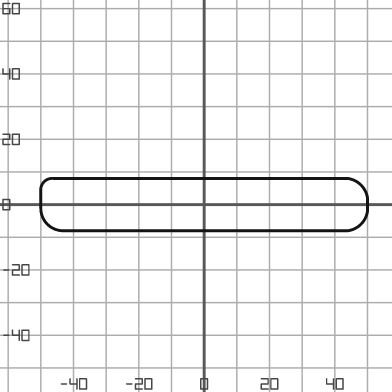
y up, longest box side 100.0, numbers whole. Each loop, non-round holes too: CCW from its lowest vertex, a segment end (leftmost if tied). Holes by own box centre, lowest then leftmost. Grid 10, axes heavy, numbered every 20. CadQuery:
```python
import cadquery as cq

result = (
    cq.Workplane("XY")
    .moveTo(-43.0, -8.0)
    .lineTo(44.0, -8.0)
    .threePointArc((48.0, -6.0), (50.0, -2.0))
    .lineTo(50.0, 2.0)
    .threePointArc((48.0, 6.0), (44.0, 8.0))
    .lineTo(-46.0, 8.0)
    .threePointArc((-49.0, 7.0), (-50.0, 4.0))
    .lineTo(-50.0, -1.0)
    .threePointArc((-48.0, -6.0), (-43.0, -8.0))
    .close()
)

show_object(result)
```